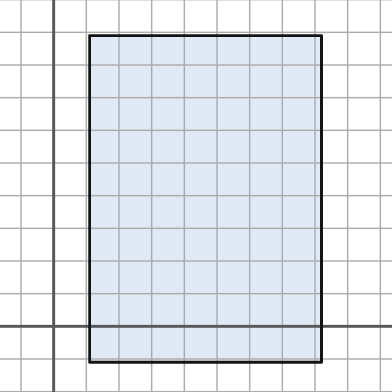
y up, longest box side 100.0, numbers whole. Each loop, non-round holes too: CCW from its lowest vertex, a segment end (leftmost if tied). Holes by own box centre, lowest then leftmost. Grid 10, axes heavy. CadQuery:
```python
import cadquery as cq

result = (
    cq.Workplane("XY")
    .moveTo(11.0, -11.0)
    .lineTo(82.0, -11.0)
    .lineTo(82.0, 89.0)
    .lineTo(11.0, 89.0)
    .close()
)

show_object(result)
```